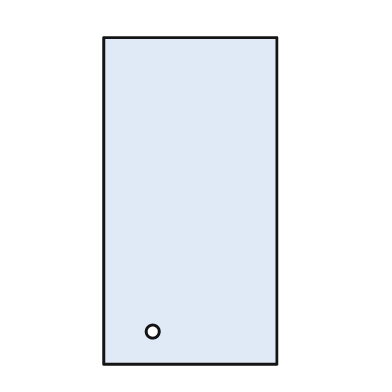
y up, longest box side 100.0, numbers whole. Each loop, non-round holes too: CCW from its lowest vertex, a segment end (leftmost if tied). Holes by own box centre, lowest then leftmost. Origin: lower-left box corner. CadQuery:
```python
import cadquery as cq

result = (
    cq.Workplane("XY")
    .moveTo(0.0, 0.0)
    .lineTo(53.0, 0.0)
    .lineTo(53.0, 100.0)
    .lineTo(0.0, 100.0)
    .close()
    .moveTo(15.0, 10.0)
    .circle(2.0)
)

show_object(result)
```